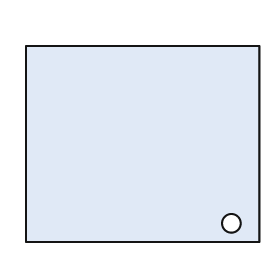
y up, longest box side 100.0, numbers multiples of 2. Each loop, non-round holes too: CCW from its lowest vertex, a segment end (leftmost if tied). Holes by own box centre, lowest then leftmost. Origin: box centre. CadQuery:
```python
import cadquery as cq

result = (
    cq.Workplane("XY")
    .moveTo(-50.0, -42.0)
    .lineTo(50.0, -42.0)
    .lineTo(50.0, 42.0)
    .lineTo(-50.0, 42.0)
    .close()
    .moveTo(38.0, -34.0)
    .circle(4.0)
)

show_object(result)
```